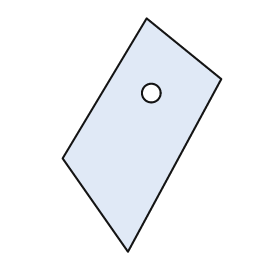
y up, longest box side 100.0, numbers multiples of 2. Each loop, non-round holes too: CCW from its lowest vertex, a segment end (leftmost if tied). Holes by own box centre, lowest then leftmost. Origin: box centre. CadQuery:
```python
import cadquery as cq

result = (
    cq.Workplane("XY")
    .moveTo(-6.0, -50.0)
    .lineTo(34.0, 24.0)
    .lineTo(2.0, 50.0)
    .lineTo(-34.0, -10.0)
    .close()
    .moveTo(4.0, 18.0)
    .circle(4.0)
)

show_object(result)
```